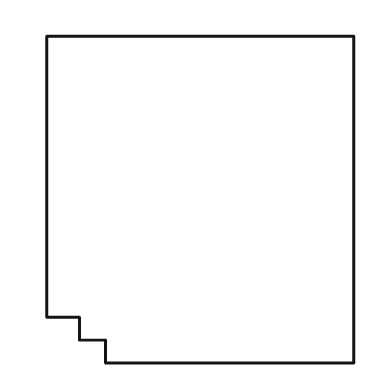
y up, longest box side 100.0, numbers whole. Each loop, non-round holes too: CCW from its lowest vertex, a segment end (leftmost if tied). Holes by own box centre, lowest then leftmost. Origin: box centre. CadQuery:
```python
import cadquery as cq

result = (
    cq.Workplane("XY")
    .moveTo(-29.0, -50.0)
    .lineTo(47.0, -50.0)
    .lineTo(47.0, 50.0)
    .lineTo(-47.0, 50.0)
    .lineTo(-47.0, -36.0)
    .lineTo(-37.0, -36.0)
    .lineTo(-37.0, -43.0)
    .lineTo(-29.0, -43.0)
    .close()
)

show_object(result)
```